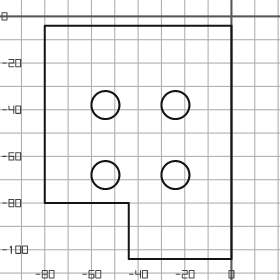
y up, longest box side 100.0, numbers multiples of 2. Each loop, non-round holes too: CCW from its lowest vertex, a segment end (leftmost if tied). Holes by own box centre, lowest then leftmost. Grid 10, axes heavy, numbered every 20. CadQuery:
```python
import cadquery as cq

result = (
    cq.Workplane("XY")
    .moveTo(-44.0, -104.0)
    .lineTo(0.0, -104.0)
    .lineTo(0.0, -4.0)
    .lineTo(-80.0, -4.0)
    .lineTo(-80.0, -80.0)
    .lineTo(-44.0, -80.0)
    .close()
    .moveTo(-54.0, -68.0)
    .circle(6.0)
    .moveTo(-24.0, -68.0)
    .circle(6.0)
    .moveTo(-54.0, -38.0)
    .circle(6.0)
    .moveTo(-24.0, -38.0)
    .circle(6.0)
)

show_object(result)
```